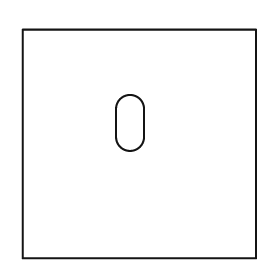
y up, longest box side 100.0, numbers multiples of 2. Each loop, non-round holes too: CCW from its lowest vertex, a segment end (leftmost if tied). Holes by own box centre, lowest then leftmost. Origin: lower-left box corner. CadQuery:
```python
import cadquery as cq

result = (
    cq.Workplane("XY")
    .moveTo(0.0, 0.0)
    .lineTo(100.0, 0.0)
    .lineTo(100.0, 98.0)
    .lineTo(0.0, 98.0)
    .close()
    .moveTo(40.0, 52.0)
    .threePointArc((46.0, 46.0), (52.0, 52.0))
    .lineTo(52.0, 64.0)
    .threePointArc((46.0, 70.0), (40.0, 64.0))
    .close()
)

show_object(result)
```